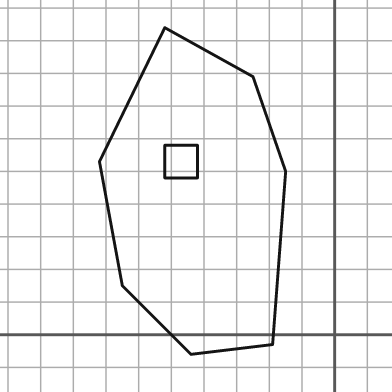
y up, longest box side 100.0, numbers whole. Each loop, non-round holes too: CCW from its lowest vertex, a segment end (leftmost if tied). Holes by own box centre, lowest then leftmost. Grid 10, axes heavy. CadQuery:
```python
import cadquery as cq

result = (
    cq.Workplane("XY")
    .moveTo(-44.0, -6.0)
    .lineTo(-19.0, -3.0)
    .lineTo(-15.0, 50.0)
    .lineTo(-25.0, 79.0)
    .lineTo(-52.0, 94.0)
    .lineTo(-72.0, 53.0)
    .lineTo(-65.0, 15.0)
    .close()
    .moveTo(-52.0, 48.0)
    .lineTo(-42.0, 48.0)
    .lineTo(-42.0, 58.0)
    .lineTo(-52.0, 58.0)
    .close()
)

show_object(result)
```